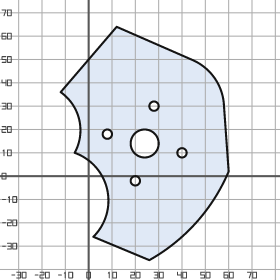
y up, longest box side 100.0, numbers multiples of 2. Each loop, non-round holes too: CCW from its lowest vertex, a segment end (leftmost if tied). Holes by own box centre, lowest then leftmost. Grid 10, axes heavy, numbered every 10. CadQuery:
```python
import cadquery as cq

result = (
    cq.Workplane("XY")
    .moveTo(26.0, -36.0)
    .threePointArc((46.0, -20.0), (60.0, 2.0))
    .lineTo(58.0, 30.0)
    .threePointArc((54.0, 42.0), (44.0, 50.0))
    .lineTo(12.0, 64.0)
    .lineTo(-12.0, 36.0)
    .threePointArc((-4.0, 24.0), (-6.0, 10.0))
    .threePointArc((8.0, -6.0), (2.0, -26.0))
    .close()
    .moveTo(20.0, -2.0)
    .circle(2.0)
    .moveTo(40.0, 10.0)
    .circle(2.0)
    .moveTo(24.0, 14.0)
    .circle(6.0)
    .moveTo(8.0, 18.0)
    .circle(2.0)
    .moveTo(28.0, 30.0)
    .circle(2.0)
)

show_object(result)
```